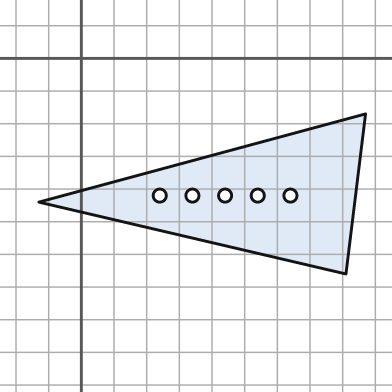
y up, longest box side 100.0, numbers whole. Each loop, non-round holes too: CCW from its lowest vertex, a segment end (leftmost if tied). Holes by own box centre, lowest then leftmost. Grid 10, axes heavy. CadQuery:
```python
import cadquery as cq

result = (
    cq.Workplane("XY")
    .moveTo(81.0, -66.0)
    .lineTo(87.0, -17.0)
    .lineTo(-13.0, -44.0)
    .close()
    .moveTo(24.0, -42.0)
    .circle(2.0)
    .moveTo(34.0, -42.0)
    .circle(2.0)
    .moveTo(44.0, -42.0)
    .circle(2.0)
    .moveTo(54.0, -42.0)
    .circle(2.0)
    .moveTo(64.0, -42.0)
    .circle(2.0)
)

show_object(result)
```